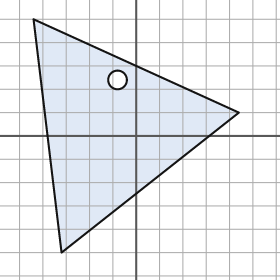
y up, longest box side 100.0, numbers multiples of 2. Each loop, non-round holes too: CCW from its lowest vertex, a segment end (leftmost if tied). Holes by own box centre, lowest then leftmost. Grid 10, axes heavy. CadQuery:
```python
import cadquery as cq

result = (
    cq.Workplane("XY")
    .moveTo(-32.0, -50.0)
    .lineTo(44.0, 10.0)
    .lineTo(-44.0, 50.0)
    .close()
    .moveTo(-8.0, 24.0)
    .circle(4.0)
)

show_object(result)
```